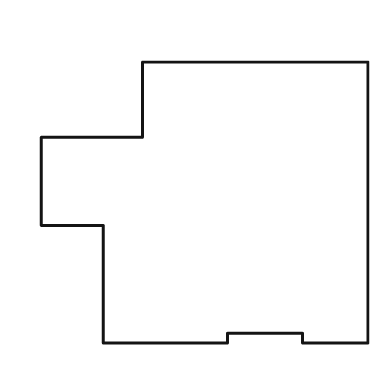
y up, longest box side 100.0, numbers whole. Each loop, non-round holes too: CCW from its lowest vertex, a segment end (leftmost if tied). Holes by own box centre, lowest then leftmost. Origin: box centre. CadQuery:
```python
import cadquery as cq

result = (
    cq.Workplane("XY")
    .moveTo(-31.0, -43.0)
    .lineTo(7.0, -43.0)
    .lineTo(7.0, -40.0)
    .lineTo(30.0, -40.0)
    .lineTo(30.0, -43.0)
    .lineTo(50.0, -43.0)
    .lineTo(50.0, 43.0)
    .lineTo(-19.0, 43.0)
    .lineTo(-19.0, 20.0)
    .lineTo(-50.0, 20.0)
    .lineTo(-50.0, -7.0)
    .lineTo(-31.0, -7.0)
    .close()
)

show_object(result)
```